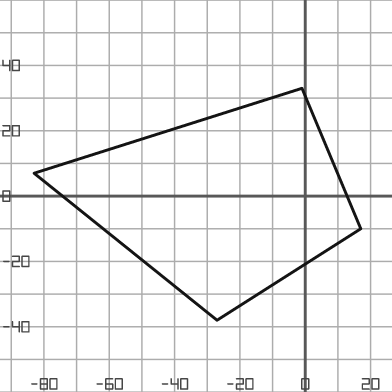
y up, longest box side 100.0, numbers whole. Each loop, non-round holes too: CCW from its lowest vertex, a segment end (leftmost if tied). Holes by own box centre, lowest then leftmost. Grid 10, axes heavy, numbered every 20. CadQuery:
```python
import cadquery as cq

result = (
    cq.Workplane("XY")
    .moveTo(-27.0, -38.0)
    .lineTo(17.0, -10.0)
    .lineTo(-1.0, 33.0)
    .lineTo(-83.0, 7.0)
    .close()
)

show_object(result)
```